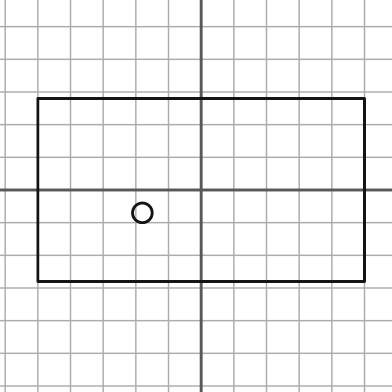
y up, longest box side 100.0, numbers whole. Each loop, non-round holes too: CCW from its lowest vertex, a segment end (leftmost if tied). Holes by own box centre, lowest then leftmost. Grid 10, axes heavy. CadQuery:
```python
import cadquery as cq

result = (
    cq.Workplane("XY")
    .moveTo(-50.0, -28.0)
    .lineTo(50.0, -28.0)
    .lineTo(50.0, 28.0)
    .lineTo(-50.0, 28.0)
    .close()
    .moveTo(-18.0, -7.0)
    .circle(3.0)
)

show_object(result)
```